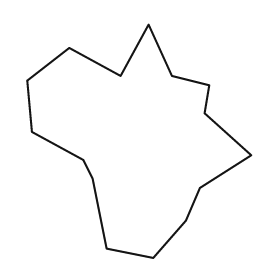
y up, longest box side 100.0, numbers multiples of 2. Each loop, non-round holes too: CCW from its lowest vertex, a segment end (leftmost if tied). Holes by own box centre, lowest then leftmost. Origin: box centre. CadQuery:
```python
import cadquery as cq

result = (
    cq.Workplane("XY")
    .moveTo(6.0, -50.0)
    .lineTo(20.0, -34.0)
    .lineTo(26.0, -20.0)
    .lineTo(48.0, -6.0)
    .lineTo(28.0, 12.0)
    .lineTo(30.0, 24.0)
    .lineTo(14.0, 28.0)
    .lineTo(4.0, 50.0)
    .lineTo(-8.0, 28.0)
    .lineTo(-30.0, 40.0)
    .lineTo(-48.0, 26.0)
    .lineTo(-46.0, 4.0)
    .lineTo(-24.0, -8.0)
    .lineTo(-20.0, -16.0)
    .lineTo(-14.0, -46.0)
    .close()
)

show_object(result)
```